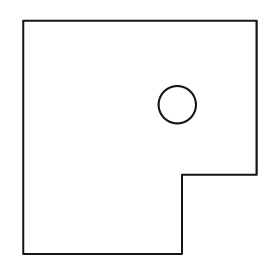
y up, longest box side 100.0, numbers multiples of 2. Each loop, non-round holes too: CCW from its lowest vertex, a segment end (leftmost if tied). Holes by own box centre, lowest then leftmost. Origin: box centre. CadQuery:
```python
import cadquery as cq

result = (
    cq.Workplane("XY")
    .moveTo(-50.0, -50.0)
    .lineTo(18.0, -50.0)
    .lineTo(18.0, -16.0)
    .lineTo(50.0, -16.0)
    .lineTo(50.0, 50.0)
    .lineTo(-50.0, 50.0)
    .close()
    .moveTo(16.0, 14.0)
    .circle(8.0)
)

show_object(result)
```